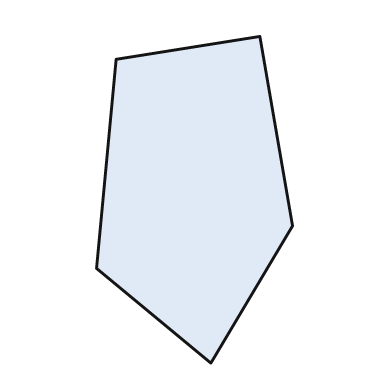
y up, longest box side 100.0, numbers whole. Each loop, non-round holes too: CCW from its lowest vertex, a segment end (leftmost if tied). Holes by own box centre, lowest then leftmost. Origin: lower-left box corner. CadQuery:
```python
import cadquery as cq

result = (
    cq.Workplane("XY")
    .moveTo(35.0, 0.0)
    .lineTo(60.0, 42.0)
    .lineTo(50.0, 100.0)
    .lineTo(6.0, 93.0)
    .lineTo(0.0, 29.0)
    .close()
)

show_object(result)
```